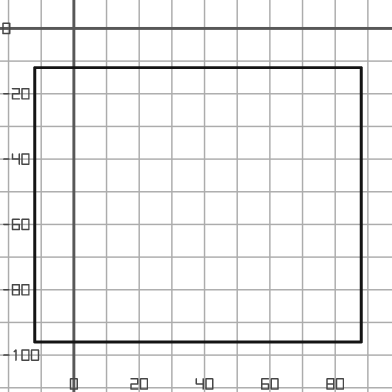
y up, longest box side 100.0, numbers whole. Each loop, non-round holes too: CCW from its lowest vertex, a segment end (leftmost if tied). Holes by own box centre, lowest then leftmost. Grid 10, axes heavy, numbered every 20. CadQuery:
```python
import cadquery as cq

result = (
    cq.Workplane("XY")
    .moveTo(-12.0, -96.0)
    .lineTo(88.0, -96.0)
    .lineTo(88.0, -12.0)
    .lineTo(-12.0, -12.0)
    .close()
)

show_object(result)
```